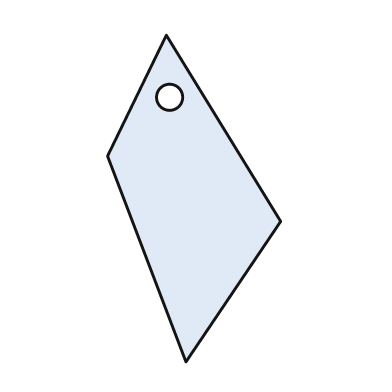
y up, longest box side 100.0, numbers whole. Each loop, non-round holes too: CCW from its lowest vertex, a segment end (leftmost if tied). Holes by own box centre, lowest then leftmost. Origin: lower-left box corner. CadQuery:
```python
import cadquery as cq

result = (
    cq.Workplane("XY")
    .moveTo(24.0, 0.0)
    .lineTo(53.0, 43.0)
    .lineTo(18.0, 100.0)
    .lineTo(0.0, 63.0)
    .close()
    .moveTo(19.0, 81.0)
    .circle(4.0)
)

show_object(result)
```